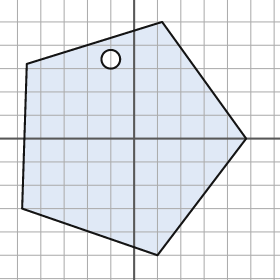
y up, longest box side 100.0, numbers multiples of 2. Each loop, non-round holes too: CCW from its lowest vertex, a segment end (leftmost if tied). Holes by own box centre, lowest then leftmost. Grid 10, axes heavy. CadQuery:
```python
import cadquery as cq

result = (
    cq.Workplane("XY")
    .moveTo(10.0, -50.0)
    .lineTo(48.0, 0.0)
    .lineTo(12.0, 50.0)
    .lineTo(-46.0, 32.0)
    .lineTo(-48.0, -30.0)
    .close()
    .moveTo(-10.0, 34.0)
    .circle(4.0)
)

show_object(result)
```